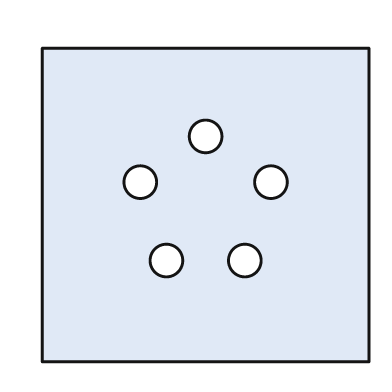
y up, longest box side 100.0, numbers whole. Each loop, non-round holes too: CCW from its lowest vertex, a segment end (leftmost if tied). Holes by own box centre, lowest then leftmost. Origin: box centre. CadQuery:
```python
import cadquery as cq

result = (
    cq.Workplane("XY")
    .moveTo(-50.0, -48.0)
    .lineTo(50.0, -48.0)
    .lineTo(50.0, 48.0)
    .lineTo(-50.0, 48.0)
    .close()
    .moveTo(-12.0, -17.0)
    .circle(5.0)
    .moveTo(12.0, -17.0)
    .circle(5.0)
    .moveTo(-20.0, 7.0)
    .circle(5.0)
    .moveTo(20.0, 7.0)
    .circle(5.0)
    .moveTo(0.0, 21.0)
    .circle(5.0)
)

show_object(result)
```